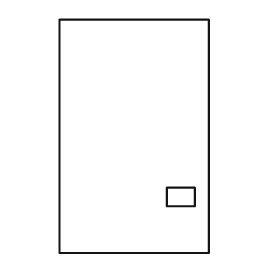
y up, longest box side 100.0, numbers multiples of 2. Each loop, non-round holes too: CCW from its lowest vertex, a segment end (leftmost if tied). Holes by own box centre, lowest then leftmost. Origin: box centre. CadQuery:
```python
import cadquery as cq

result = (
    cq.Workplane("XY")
    .moveTo(-32.0, -50.0)
    .lineTo(32.0, -50.0)
    .lineTo(32.0, 50.0)
    .lineTo(-32.0, 50.0)
    .close()
    .moveTo(14.0, -30.0)
    .lineTo(26.0, -30.0)
    .lineTo(26.0, -22.0)
    .lineTo(14.0, -22.0)
    .close()
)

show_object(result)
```